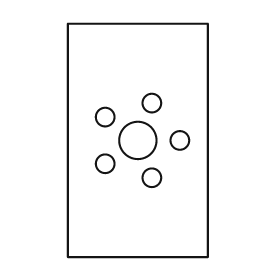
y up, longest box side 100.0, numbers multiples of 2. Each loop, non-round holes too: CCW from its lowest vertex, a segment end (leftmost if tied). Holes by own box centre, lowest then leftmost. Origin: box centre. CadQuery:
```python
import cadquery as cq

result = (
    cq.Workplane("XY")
    .moveTo(-30.0, -50.0)
    .lineTo(30.0, -50.0)
    .lineTo(30.0, 50.0)
    .lineTo(-30.0, 50.0)
    .close()
    .moveTo(6.0, -16.0)
    .circle(4.0)
    .moveTo(-14.0, -10.0)
    .circle(4.0)
    .moveTo(0.0, 0.0)
    .circle(8.0)
    .moveTo(18.0, 0.0)
    .circle(4.0)
    .moveTo(-14.0, 10.0)
    .circle(4.0)
    .moveTo(6.0, 16.0)
    .circle(4.0)
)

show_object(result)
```